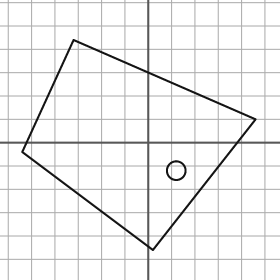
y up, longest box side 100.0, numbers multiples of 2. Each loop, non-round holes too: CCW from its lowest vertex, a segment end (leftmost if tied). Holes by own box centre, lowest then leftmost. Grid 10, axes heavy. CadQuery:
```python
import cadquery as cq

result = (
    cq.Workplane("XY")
    .moveTo(2.0, -46.0)
    .lineTo(46.0, 10.0)
    .lineTo(-32.0, 44.0)
    .lineTo(-54.0, -4.0)
    .close()
    .moveTo(12.0, -12.0)
    .circle(4.0)
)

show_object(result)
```